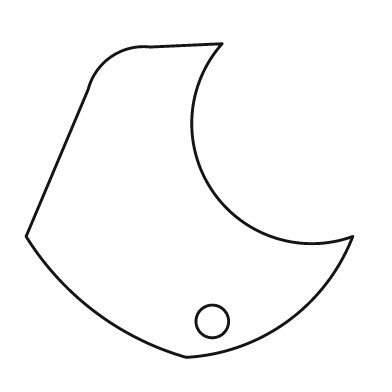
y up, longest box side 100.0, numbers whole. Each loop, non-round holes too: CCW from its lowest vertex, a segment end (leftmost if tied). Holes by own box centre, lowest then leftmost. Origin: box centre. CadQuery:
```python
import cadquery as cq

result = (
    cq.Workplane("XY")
    .moveTo(-1.0, -48.0)
    .threePointArc((30.0, -37.0), (50.0, -11.0))
    .threePointArc((7.0, 3.0), (10.0, 48.0))
    .lineTo(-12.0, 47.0)
    .threePointArc((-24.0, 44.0), (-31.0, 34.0))
    .lineTo(-50.0, -11.0)
    .threePointArc((-29.0, -34.0), (-1.0, -48.0))
    .close()
    .moveTo(7.0, -37.0)
    .circle(5.0)
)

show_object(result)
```